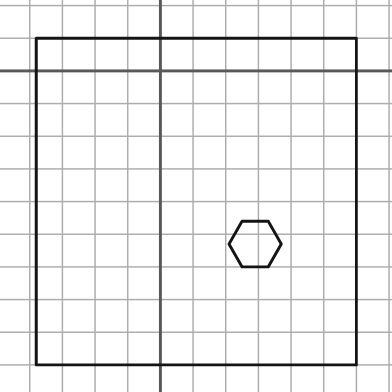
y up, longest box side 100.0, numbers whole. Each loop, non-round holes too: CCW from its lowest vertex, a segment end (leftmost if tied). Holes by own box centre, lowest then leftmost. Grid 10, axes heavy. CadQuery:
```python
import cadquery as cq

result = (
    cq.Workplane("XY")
    .moveTo(-38.0, -90.0)
    .lineTo(60.0, -90.0)
    .lineTo(60.0, 10.0)
    .lineTo(-38.0, 10.0)
    .close()
    .moveTo(25.0, -60.0)
    .lineTo(33.0, -60.0)
    .lineTo(37.0, -53.0)
    .lineTo(33.0, -46.0)
    .lineTo(25.0, -46.0)
    .lineTo(21.0, -53.0)
    .close()
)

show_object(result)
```